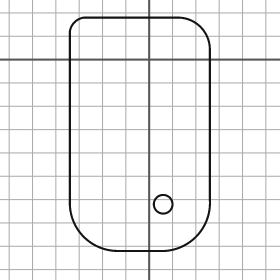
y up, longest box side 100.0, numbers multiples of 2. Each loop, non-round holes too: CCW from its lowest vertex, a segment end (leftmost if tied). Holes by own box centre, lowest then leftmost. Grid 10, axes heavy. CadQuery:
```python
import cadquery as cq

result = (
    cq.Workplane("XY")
    .moveTo(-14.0, -82.0)
    .lineTo(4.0, -82.0)
    .threePointArc((20.0, -76.0), (26.0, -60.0))
    .lineTo(26.0, 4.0)
    .threePointArc((22.0, 14.0), (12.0, 18.0))
    .lineTo(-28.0, 18.0)
    .threePointArc((-32.0, 16.0), (-34.0, 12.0))
    .lineTo(-34.0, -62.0)
    .threePointArc((-28.0, -76.0), (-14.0, -82.0))
    .close()
    .moveTo(6.0, -62.0)
    .circle(4.0)
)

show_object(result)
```